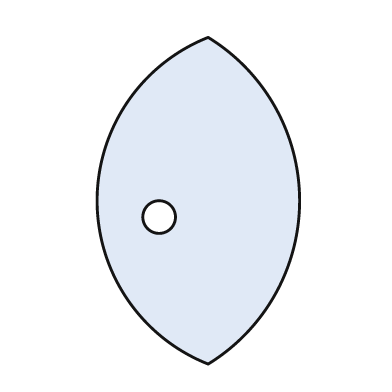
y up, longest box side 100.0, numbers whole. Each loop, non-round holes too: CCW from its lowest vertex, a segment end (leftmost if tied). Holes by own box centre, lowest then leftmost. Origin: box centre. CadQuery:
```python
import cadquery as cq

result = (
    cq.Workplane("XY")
    .moveTo(3.0, -50.0)
    .threePointArc((31.0, 0.0), (3.0, 50.0))
    .threePointArc((-31.0, 0.0), (3.0, -50.0))
    .close()
    .moveTo(-12.0, -5.0)
    .circle(5.0)
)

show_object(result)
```